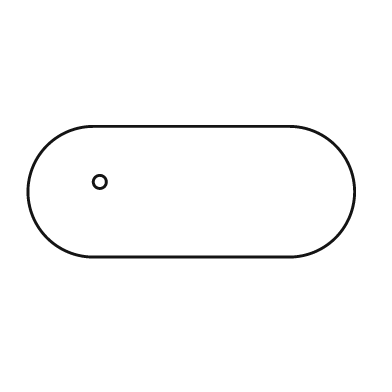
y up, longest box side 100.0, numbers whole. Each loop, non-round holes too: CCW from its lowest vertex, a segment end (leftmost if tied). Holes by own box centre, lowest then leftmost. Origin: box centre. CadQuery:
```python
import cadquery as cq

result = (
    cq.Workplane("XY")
    .moveTo(-30.0, -20.0)
    .lineTo(30.0, -20.0)
    .threePointArc((50.0, 0.0), (30.0, 20.0))
    .lineTo(-30.0, 20.0)
    .threePointArc((-50.0, 0.0), (-30.0, -20.0))
    .close()
    .moveTo(-28.0, 3.0)
    .circle(2.0)
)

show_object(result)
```